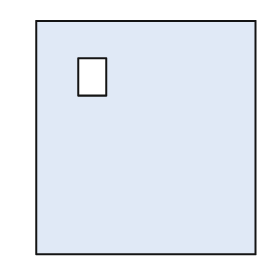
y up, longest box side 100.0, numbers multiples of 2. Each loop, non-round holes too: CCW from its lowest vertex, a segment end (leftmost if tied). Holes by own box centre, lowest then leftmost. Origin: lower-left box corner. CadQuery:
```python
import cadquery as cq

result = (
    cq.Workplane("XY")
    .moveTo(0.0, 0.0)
    .lineTo(94.0, 0.0)
    .lineTo(94.0, 100.0)
    .lineTo(0.0, 100.0)
    .close()
    .moveTo(18.0, 68.0)
    .lineTo(30.0, 68.0)
    .lineTo(30.0, 84.0)
    .lineTo(18.0, 84.0)
    .close()
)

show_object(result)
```